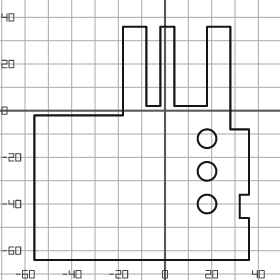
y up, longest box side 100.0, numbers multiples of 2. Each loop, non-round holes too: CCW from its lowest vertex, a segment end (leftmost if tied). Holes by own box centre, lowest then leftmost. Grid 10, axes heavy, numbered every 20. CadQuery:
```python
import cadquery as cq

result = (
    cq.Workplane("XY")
    .moveTo(-56.0, -64.0)
    .lineTo(36.0, -64.0)
    .lineTo(36.0, -46.0)
    .lineTo(32.0, -46.0)
    .lineTo(32.0, -36.0)
    .lineTo(36.0, -36.0)
    .lineTo(36.0, -8.0)
    .lineTo(28.0, -8.0)
    .lineTo(28.0, 36.0)
    .lineTo(18.0, 36.0)
    .lineTo(18.0, 2.0)
    .lineTo(4.0, 2.0)
    .lineTo(4.0, 36.0)
    .lineTo(-2.0, 36.0)
    .lineTo(-2.0, 2.0)
    .lineTo(-8.0, 2.0)
    .lineTo(-8.0, 36.0)
    .lineTo(-18.0, 36.0)
    .lineTo(-18.0, -2.0)
    .lineTo(-56.0, -2.0)
    .close()
    .moveTo(18.0, -40.0)
    .circle(4.0)
    .moveTo(18.0, -26.0)
    .circle(4.0)
    .moveTo(18.0, -12.0)
    .circle(4.0)
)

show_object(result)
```